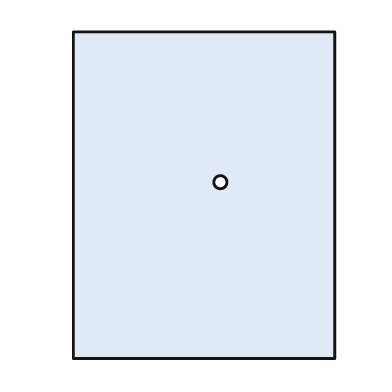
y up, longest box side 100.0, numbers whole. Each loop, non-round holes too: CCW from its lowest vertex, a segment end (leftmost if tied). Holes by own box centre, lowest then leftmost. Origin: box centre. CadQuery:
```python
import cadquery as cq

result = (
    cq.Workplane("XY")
    .moveTo(-40.0, -50.0)
    .lineTo(40.0, -50.0)
    .lineTo(40.0, 50.0)
    .lineTo(-40.0, 50.0)
    .close()
    .moveTo(5.0, 4.0)
    .circle(2.0)
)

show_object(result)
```